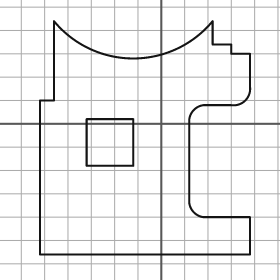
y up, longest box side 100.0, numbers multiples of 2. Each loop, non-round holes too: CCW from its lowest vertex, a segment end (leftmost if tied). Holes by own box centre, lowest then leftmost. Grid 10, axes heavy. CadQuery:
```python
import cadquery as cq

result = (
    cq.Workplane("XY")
    .moveTo(-52.0, -56.0)
    .lineTo(38.0, -56.0)
    .lineTo(38.0, -40.0)
    .lineTo(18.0, -40.0)
    .threePointArc((14.0, -38.0), (12.0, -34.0))
    .lineTo(12.0, 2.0)
    .threePointArc((14.0, 6.0), (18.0, 8.0))
    .lineTo(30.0, 8.0)
    .threePointArc((36.0, 10.0), (38.0, 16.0))
    .lineTo(38.0, 30.0)
    .lineTo(30.0, 30.0)
    .lineTo(30.0, 34.0)
    .lineTo(22.0, 34.0)
    .lineTo(22.0, 44.0)
    .threePointArc((-12.0, 28.0), (-46.0, 44.0))
    .lineTo(-46.0, 10.0)
    .lineTo(-52.0, 10.0)
    .close()
    .moveTo(-32.0, -18.0)
    .lineTo(-12.0, -18.0)
    .lineTo(-12.0, 2.0)
    .lineTo(-32.0, 2.0)
    .close()
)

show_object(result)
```